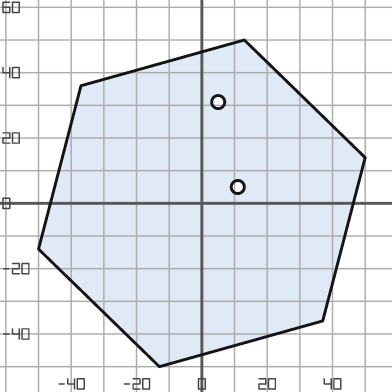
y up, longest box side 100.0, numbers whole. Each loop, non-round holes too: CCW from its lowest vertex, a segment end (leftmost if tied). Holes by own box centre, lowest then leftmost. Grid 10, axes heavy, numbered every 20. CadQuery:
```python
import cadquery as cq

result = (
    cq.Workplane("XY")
    .moveTo(-13.0, -50.0)
    .lineTo(37.0, -36.0)
    .lineTo(50.0, 14.0)
    .lineTo(13.0, 50.0)
    .lineTo(-37.0, 36.0)
    .lineTo(-50.0, -14.0)
    .close()
    .moveTo(11.0, 5.0)
    .circle(2.0)
    .moveTo(5.0, 31.0)
    .circle(2.0)
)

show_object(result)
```